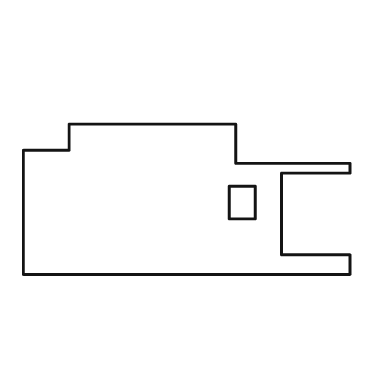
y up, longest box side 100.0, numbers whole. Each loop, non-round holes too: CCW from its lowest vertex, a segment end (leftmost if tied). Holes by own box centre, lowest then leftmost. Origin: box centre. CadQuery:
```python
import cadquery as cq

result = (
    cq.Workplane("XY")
    .moveTo(-50.0, -23.0)
    .lineTo(50.0, -23.0)
    .lineTo(50.0, -17.0)
    .lineTo(29.0, -17.0)
    .lineTo(29.0, 8.0)
    .lineTo(50.0, 8.0)
    .lineTo(50.0, 11.0)
    .lineTo(15.0, 11.0)
    .lineTo(15.0, 23.0)
    .lineTo(-36.0, 23.0)
    .lineTo(-36.0, 15.0)
    .lineTo(-50.0, 15.0)
    .close()
    .moveTo(13.0, -6.0)
    .lineTo(21.0, -6.0)
    .lineTo(21.0, 4.0)
    .lineTo(13.0, 4.0)
    .close()
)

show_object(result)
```